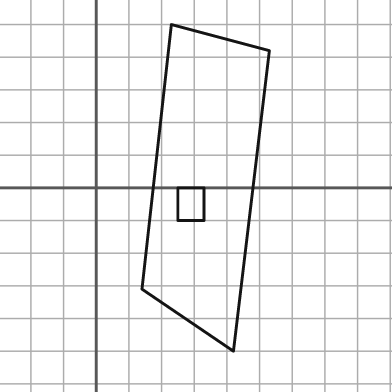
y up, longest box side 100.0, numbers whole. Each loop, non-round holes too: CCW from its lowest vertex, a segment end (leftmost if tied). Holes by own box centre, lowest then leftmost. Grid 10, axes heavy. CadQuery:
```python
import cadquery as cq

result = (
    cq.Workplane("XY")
    .moveTo(42.0, -50.0)
    .lineTo(53.0, 42.0)
    .lineTo(23.0, 50.0)
    .lineTo(14.0, -31.0)
    .close()
    .moveTo(25.0, -10.0)
    .lineTo(33.0, -10.0)
    .lineTo(33.0, 0.0)
    .lineTo(25.0, 0.0)
    .close()
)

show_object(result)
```